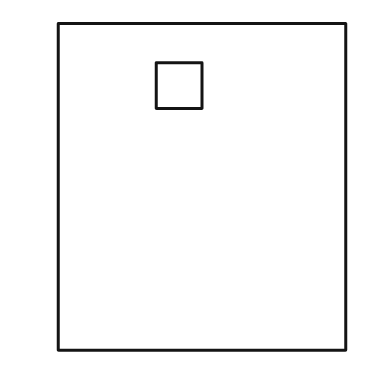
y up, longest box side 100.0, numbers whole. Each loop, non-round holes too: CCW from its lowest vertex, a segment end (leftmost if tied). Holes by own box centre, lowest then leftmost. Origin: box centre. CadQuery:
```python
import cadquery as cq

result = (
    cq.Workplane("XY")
    .moveTo(-44.0, -50.0)
    .lineTo(44.0, -50.0)
    .lineTo(44.0, 50.0)
    .lineTo(-44.0, 50.0)
    .close()
    .moveTo(-14.0, 24.0)
    .lineTo(0.0, 24.0)
    .lineTo(0.0, 38.0)
    .lineTo(-14.0, 38.0)
    .close()
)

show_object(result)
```